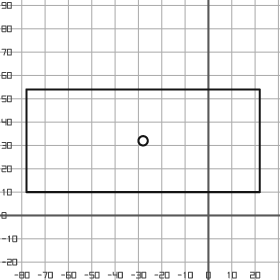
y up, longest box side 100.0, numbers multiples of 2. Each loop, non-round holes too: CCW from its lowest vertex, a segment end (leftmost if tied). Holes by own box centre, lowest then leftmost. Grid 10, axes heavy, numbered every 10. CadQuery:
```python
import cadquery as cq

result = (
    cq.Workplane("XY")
    .moveTo(-78.0, 10.0)
    .lineTo(22.0, 10.0)
    .lineTo(22.0, 54.0)
    .lineTo(-78.0, 54.0)
    .close()
    .moveTo(-28.0, 32.0)
    .circle(2.0)
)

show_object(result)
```